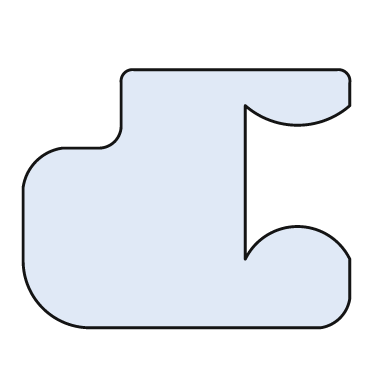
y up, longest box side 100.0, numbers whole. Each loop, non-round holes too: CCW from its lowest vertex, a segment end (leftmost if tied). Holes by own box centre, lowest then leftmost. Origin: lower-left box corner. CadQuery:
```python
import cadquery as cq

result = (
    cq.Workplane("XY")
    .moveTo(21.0, 0.0)
    .lineTo(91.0, 0.0)
    .threePointArc((97.0, 3.0), (100.0, 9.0))
    .lineTo(100.0, 21.0)
    .threePointArc((84.0, 31.0), (68.0, 21.0))
    .lineTo(68.0, 68.0)
    .threePointArc((84.0, 62.0), (100.0, 68.0))
    .lineTo(100.0, 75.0)
    .threePointArc((99.0, 78.0), (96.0, 79.0))
    .lineTo(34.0, 79.0)
    .threePointArc((31.0, 78.0), (30.0, 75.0))
    .lineTo(30.0, 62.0)
    .threePointArc((28.0, 57.0), (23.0, 55.0))
    .lineTo(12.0, 55.0)
    .threePointArc((4.0, 51.0), (0.0, 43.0))
    .lineTo(0.0, 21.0)
    .threePointArc((6.0, 6.0), (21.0, 0.0))
    .close()
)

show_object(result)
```